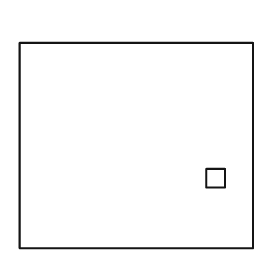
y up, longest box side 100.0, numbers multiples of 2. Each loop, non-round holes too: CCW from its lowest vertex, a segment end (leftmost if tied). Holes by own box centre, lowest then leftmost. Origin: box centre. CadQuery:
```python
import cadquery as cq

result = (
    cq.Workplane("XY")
    .moveTo(-50.0, -44.0)
    .lineTo(50.0, -44.0)
    .lineTo(50.0, 44.0)
    .lineTo(-50.0, 44.0)
    .close()
    .moveTo(30.0, -18.0)
    .lineTo(38.0, -18.0)
    .lineTo(38.0, -10.0)
    .lineTo(30.0, -10.0)
    .close()
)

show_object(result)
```